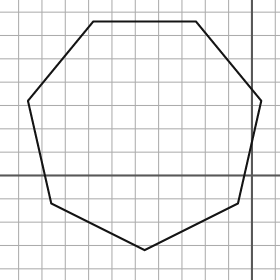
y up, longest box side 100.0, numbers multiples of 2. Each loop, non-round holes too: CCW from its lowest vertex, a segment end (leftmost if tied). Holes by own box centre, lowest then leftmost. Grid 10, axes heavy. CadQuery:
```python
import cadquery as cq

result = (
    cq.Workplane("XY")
    .moveTo(-46.0, -32.0)
    .lineTo(-6.0, -12.0)
    .lineTo(4.0, 32.0)
    .lineTo(-24.0, 66.0)
    .lineTo(-68.0, 66.0)
    .lineTo(-96.0, 32.0)
    .lineTo(-86.0, -12.0)
    .close()
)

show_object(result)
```